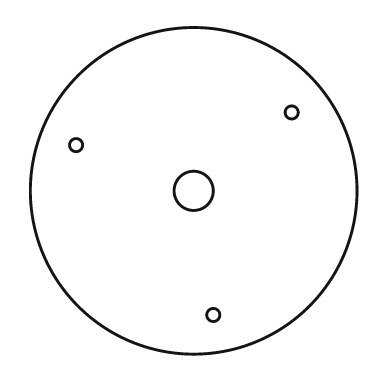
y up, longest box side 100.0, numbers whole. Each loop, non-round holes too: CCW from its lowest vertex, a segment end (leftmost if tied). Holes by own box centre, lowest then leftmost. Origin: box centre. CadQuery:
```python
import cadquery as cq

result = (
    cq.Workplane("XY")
    .moveTo(0.0, 0.0)
    .circle(50.0)
    .moveTo(6.0, -38.0)
    .circle(2.0)
    .moveTo(0.0, 0.0)
    .circle(6.0)
    .moveTo(-36.0, 14.0)
    .circle(2.0)
    .moveTo(30.0, 24.0)
    .circle(2.0)
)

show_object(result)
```